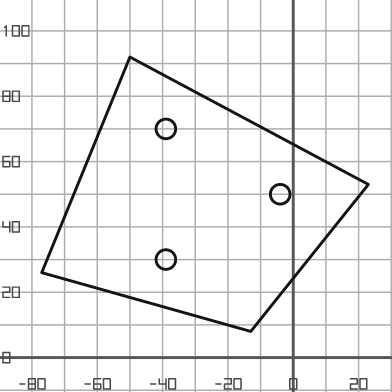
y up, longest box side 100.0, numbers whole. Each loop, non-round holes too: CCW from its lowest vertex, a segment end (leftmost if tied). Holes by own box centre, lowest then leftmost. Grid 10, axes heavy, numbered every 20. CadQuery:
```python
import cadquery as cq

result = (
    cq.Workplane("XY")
    .moveTo(-13.0, 8.0)
    .lineTo(23.0, 53.0)
    .lineTo(-50.0, 92.0)
    .lineTo(-77.0, 26.0)
    .close()
    .moveTo(-39.0, 30.0)
    .circle(3.0)
    .moveTo(-4.0, 50.0)
    .circle(3.0)
    .moveTo(-39.0, 70.0)
    .circle(3.0)
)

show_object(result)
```